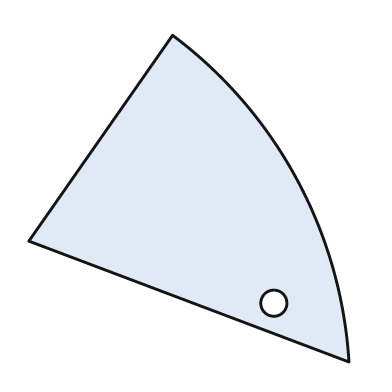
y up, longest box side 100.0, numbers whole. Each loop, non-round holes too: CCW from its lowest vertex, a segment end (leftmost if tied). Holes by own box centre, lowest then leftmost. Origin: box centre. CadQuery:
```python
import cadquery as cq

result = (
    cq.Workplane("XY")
    .moveTo(49.0, -50.0)
    .threePointArc((33.0, 6.0), (-5.0, 50.0))
    .lineTo(-49.0, -13.0)
    .close()
    .moveTo(26.0, -32.0)
    .circle(4.0)
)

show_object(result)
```